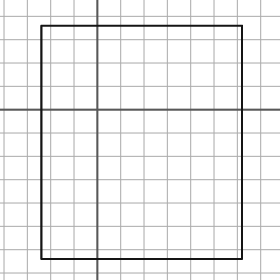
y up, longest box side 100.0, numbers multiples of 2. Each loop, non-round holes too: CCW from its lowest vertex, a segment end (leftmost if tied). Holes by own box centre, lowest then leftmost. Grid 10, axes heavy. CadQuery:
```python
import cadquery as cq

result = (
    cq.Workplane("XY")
    .moveTo(-24.0, -64.0)
    .lineTo(62.0, -64.0)
    .lineTo(62.0, 36.0)
    .lineTo(-24.0, 36.0)
    .close()
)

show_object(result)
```